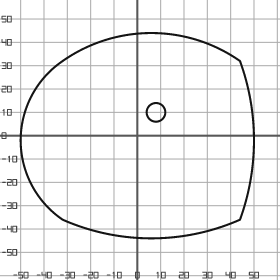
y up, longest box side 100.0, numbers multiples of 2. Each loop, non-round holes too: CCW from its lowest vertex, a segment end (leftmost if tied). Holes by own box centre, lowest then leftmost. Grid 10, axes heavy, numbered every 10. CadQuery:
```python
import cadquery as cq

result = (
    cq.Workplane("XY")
    .moveTo(-32.0, -36.0)
    .threePointArc((6.0, -44.0), (44.0, -36.0))
    .threePointArc((50.0, -2.0), (44.0, 32.0))
    .threePointArc((6.0, 44.0), (-32.0, 32.0))
    .threePointArc((-50.0, -2.0), (-32.0, -36.0))
    .close()
    .moveTo(8.0, 10.0)
    .circle(4.0)
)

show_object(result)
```